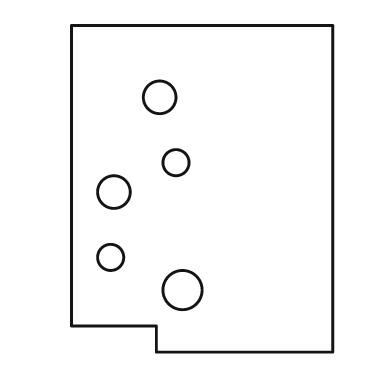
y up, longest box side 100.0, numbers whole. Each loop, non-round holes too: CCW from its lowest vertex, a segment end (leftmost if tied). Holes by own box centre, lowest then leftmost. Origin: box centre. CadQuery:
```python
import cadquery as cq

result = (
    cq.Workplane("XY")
    .moveTo(-14.0, -50.0)
    .lineTo(40.0, -50.0)
    .lineTo(40.0, 50.0)
    .lineTo(-40.0, 50.0)
    .lineTo(-40.0, -42.0)
    .lineTo(-14.0, -42.0)
    .close()
    .moveTo(-6.0, -31.0)
    .circle(6.0)
    .moveTo(-28.0, -21.0)
    .circle(4.0)
    .moveTo(-27.0, -1.0)
    .circle(5.0)
    .moveTo(-8.0, 8.0)
    .circle(4.0)
    .moveTo(-13.0, 28.0)
    .circle(5.0)
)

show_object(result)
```